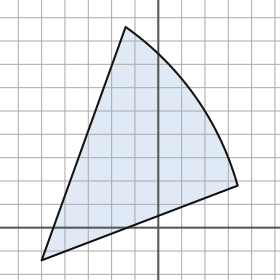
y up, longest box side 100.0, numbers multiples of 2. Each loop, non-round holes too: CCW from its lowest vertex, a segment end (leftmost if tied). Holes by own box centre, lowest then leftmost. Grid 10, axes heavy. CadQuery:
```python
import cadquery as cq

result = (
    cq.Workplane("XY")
    .moveTo(-50.0, -14.0)
    .lineTo(34.0, 18.0)
    .threePointArc((16.0, 56.0), (-14.0, 86.0))
    .close()
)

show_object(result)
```